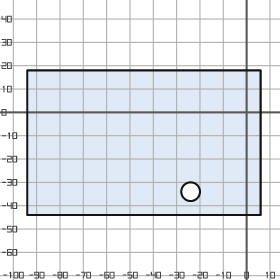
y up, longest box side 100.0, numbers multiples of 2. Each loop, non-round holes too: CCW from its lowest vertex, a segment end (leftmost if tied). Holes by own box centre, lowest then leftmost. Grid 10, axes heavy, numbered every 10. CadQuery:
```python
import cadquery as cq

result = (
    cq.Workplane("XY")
    .moveTo(-94.0, -44.0)
    .lineTo(6.0, -44.0)
    .lineTo(6.0, 18.0)
    .lineTo(-94.0, 18.0)
    .close()
    .moveTo(-24.0, -34.0)
    .circle(4.0)
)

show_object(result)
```